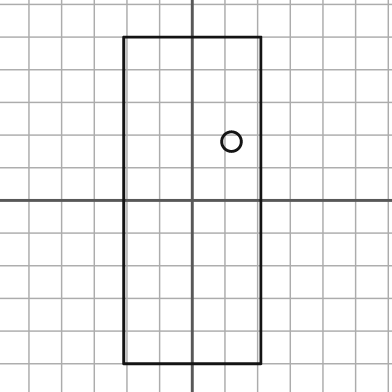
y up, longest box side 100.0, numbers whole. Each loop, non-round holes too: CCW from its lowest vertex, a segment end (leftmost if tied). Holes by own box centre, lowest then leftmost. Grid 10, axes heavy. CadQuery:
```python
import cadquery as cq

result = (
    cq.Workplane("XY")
    .moveTo(-21.0, -50.0)
    .lineTo(21.0, -50.0)
    .lineTo(21.0, 50.0)
    .lineTo(-21.0, 50.0)
    .close()
    .moveTo(12.0, 18.0)
    .circle(3.0)
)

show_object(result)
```